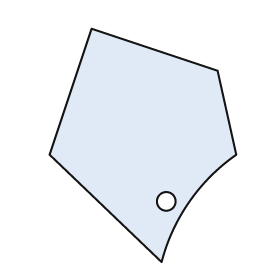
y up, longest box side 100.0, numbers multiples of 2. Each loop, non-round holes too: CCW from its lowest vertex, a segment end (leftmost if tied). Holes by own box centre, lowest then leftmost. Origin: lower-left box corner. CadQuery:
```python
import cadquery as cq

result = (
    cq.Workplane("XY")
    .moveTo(48.0, 0.0)
    .threePointArc((60.0, 26.0), (80.0, 46.0))
    .lineTo(72.0, 82.0)
    .lineTo(18.0, 100.0)
    .lineTo(0.0, 46.0)
    .close()
    .moveTo(50.0, 26.0)
    .circle(4.0)
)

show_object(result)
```